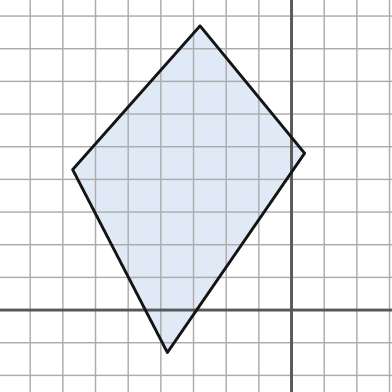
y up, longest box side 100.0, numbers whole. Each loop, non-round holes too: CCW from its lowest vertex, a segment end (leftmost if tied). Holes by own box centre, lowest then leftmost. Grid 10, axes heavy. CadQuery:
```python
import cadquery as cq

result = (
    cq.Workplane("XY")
    .moveTo(-38.0, -13.0)
    .lineTo(4.0, 48.0)
    .lineTo(-28.0, 87.0)
    .lineTo(-67.0, 43.0)
    .close()
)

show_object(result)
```